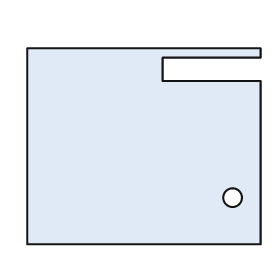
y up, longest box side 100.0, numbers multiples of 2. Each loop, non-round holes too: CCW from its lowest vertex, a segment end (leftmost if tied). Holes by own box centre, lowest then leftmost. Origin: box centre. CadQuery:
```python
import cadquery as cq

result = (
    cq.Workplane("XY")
    .moveTo(-50.0, -42.0)
    .lineTo(50.0, -42.0)
    .lineTo(50.0, 28.0)
    .lineTo(8.0, 28.0)
    .lineTo(8.0, 38.0)
    .lineTo(50.0, 38.0)
    .lineTo(50.0, 42.0)
    .lineTo(-50.0, 42.0)
    .close()
    .moveTo(38.0, -22.0)
    .circle(4.0)
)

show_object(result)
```